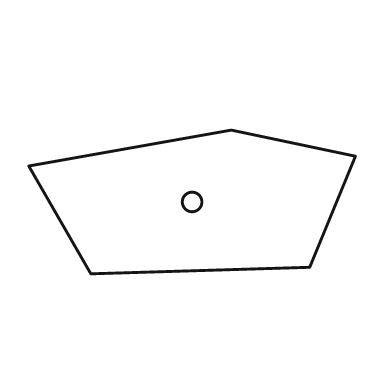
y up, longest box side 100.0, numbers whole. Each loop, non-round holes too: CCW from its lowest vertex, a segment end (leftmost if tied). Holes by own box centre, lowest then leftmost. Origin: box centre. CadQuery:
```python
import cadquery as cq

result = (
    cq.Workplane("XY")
    .moveTo(-31.0, -22.0)
    .lineTo(36.0, -20.0)
    .lineTo(50.0, 14.0)
    .lineTo(12.0, 22.0)
    .lineTo(-50.0, 11.0)
    .close()
    .moveTo(0.0, 0.0)
    .circle(3.0)
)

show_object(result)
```